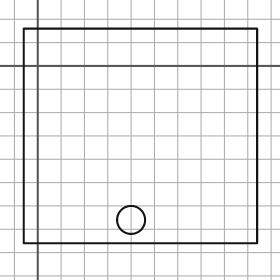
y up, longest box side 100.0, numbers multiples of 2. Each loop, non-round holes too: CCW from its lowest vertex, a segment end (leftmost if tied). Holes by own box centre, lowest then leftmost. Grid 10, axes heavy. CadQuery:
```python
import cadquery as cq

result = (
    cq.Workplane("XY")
    .moveTo(-6.0, -76.0)
    .lineTo(94.0, -76.0)
    .lineTo(94.0, 16.0)
    .lineTo(-6.0, 16.0)
    .close()
    .moveTo(40.0, -66.0)
    .circle(6.0)
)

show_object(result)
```